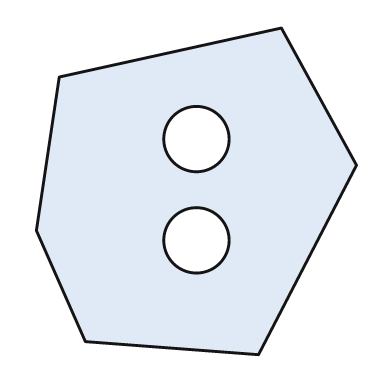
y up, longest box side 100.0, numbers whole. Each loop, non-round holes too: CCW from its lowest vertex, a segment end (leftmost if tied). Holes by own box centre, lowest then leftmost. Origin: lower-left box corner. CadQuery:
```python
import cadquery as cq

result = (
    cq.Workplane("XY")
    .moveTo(68.0, 0.0)
    .lineTo(98.0, 58.0)
    .lineTo(75.0, 100.0)
    .lineTo(7.0, 85.0)
    .lineTo(0.0, 38.0)
    .lineTo(15.0, 4.0)
    .close()
    .moveTo(49.0, 35.0)
    .circle(10.0)
    .moveTo(49.0, 66.0)
    .circle(10.0)
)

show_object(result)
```